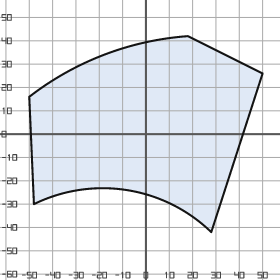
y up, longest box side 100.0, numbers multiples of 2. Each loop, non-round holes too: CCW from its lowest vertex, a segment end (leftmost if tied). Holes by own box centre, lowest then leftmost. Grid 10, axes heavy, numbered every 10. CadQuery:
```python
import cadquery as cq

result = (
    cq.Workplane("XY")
    .moveTo(28.0, -42.0)
    .lineTo(50.0, 26.0)
    .lineTo(18.0, 42.0)
    .threePointArc((-18.0, 34.0), (-50.0, 16.0))
    .lineTo(-48.0, -30.0)
    .threePointArc((-8.0, -24.0), (28.0, -42.0))
    .close()
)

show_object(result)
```